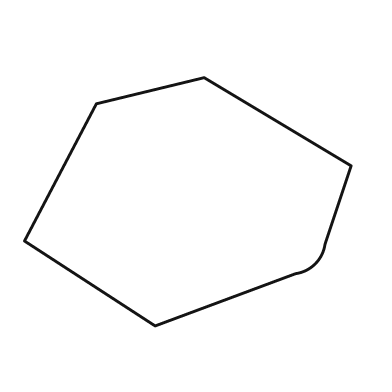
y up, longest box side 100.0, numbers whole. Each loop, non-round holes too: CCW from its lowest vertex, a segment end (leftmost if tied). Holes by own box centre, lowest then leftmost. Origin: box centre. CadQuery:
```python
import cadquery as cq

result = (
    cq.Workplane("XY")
    .moveTo(-10.0, -38.0)
    .lineTo(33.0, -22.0)
    .threePointArc((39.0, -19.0), (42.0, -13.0))
    .lineTo(50.0, 11.0)
    .lineTo(5.0, 38.0)
    .lineTo(-28.0, 30.0)
    .lineTo(-50.0, -12.0)
    .close()
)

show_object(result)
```